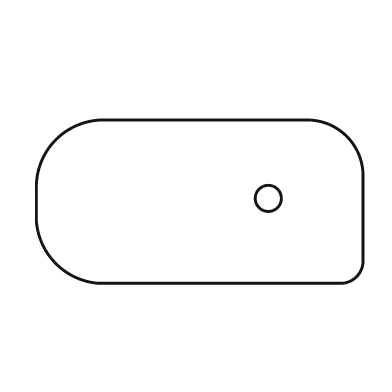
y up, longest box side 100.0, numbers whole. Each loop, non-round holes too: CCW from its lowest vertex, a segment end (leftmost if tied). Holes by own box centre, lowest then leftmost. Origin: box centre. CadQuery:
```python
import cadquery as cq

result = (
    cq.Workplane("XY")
    .moveTo(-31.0, -25.0)
    .lineTo(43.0, -25.0)
    .threePointArc((48.0, -23.0), (50.0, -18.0))
    .lineTo(50.0, 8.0)
    .threePointArc((45.0, 20.0), (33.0, 25.0))
    .lineTo(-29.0, 25.0)
    .threePointArc((-44.0, 19.0), (-50.0, 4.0))
    .lineTo(-50.0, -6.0)
    .threePointArc((-44.0, -19.0), (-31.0, -25.0))
    .close()
    .moveTo(21.0, 1.0)
    .circle(4.0)
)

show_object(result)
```